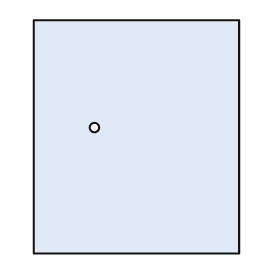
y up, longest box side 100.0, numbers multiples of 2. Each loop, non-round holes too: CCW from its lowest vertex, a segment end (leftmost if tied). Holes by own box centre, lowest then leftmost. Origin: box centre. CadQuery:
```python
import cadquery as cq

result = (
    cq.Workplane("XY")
    .moveTo(-44.0, -50.0)
    .lineTo(44.0, -50.0)
    .lineTo(44.0, 50.0)
    .lineTo(-44.0, 50.0)
    .close()
    .moveTo(-18.0, 4.0)
    .circle(2.0)
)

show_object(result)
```